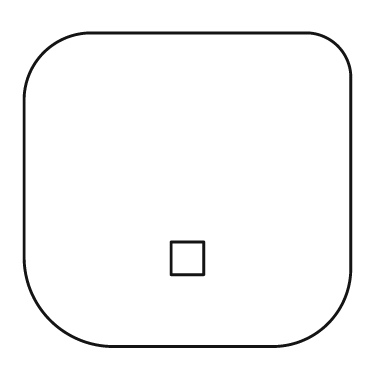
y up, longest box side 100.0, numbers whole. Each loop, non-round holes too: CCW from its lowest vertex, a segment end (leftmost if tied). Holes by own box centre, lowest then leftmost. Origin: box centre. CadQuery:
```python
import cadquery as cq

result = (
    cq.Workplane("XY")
    .moveTo(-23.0, -48.0)
    .lineTo(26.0, -48.0)
    .threePointArc((43.0, -41.0), (50.0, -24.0))
    .lineTo(50.0, 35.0)
    .threePointArc((46.0, 44.0), (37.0, 48.0))
    .lineTo(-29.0, 48.0)
    .threePointArc((-44.0, 42.0), (-50.0, 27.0))
    .lineTo(-50.0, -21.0)
    .threePointArc((-42.0, -40.0), (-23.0, -48.0))
    .close()
    .moveTo(-5.0, -26.0)
    .lineTo(5.0, -26.0)
    .lineTo(5.0, -16.0)
    .lineTo(-5.0, -16.0)
    .close()
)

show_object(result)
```